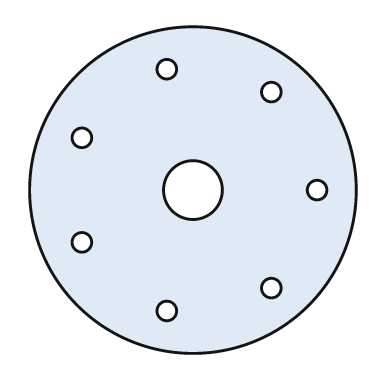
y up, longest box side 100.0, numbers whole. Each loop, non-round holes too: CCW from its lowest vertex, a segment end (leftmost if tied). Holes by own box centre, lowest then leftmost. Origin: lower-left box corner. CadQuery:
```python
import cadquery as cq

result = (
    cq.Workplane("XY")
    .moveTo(50.0, 50.0)
    .circle(50.0)
    .moveTo(42.0, 13.0)
    .circle(3.0)
    .moveTo(74.0, 20.0)
    .circle(3.0)
    .moveTo(16.0, 34.0)
    .circle(3.0)
    .moveTo(50.0, 50.0)
    .circle(9.0)
    .moveTo(88.0, 50.0)
    .circle(3.0)
    .moveTo(16.0, 66.0)
    .circle(3.0)
    .moveTo(74.0, 80.0)
    .circle(3.0)
    .moveTo(42.0, 87.0)
    .circle(3.0)
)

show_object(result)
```